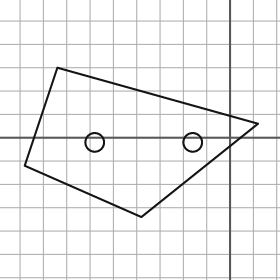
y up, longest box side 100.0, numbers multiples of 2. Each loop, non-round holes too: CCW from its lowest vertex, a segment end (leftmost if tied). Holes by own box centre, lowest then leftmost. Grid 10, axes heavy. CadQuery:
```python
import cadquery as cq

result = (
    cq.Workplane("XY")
    .moveTo(-38.0, -34.0)
    .lineTo(12.0, 6.0)
    .lineTo(-74.0, 30.0)
    .lineTo(-88.0, -12.0)
    .close()
    .moveTo(-58.0, -2.0)
    .circle(4.0)
    .moveTo(-16.0, -2.0)
    .circle(4.0)
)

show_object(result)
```